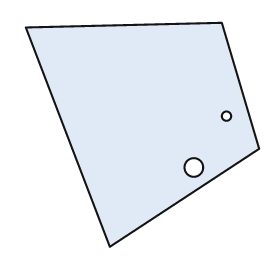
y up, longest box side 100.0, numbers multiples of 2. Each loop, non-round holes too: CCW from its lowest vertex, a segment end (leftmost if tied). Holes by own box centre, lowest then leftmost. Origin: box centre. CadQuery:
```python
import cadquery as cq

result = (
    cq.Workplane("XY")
    .moveTo(-14.0, -48.0)
    .lineTo(50.0, -6.0)
    .lineTo(34.0, 48.0)
    .lineTo(-50.0, 46.0)
    .close()
    .moveTo(22.0, -14.0)
    .circle(4.0)
    .moveTo(36.0, 8.0)
    .circle(2.0)
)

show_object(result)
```